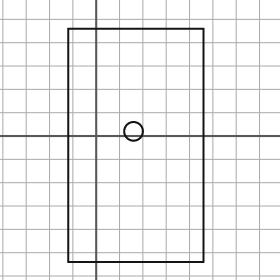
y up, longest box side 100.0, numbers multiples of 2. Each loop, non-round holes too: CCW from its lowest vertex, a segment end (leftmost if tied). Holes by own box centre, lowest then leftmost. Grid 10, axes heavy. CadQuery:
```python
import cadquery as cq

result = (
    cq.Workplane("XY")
    .moveTo(-12.0, -54.0)
    .lineTo(46.0, -54.0)
    .lineTo(46.0, 46.0)
    .lineTo(-12.0, 46.0)
    .close()
    .moveTo(16.0, 2.0)
    .circle(4.0)
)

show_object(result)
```